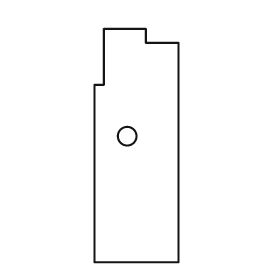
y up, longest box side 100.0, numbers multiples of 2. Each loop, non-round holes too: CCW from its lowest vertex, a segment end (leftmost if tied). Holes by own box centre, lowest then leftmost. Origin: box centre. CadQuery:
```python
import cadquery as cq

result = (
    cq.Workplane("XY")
    .moveTo(-18.0, -50.0)
    .lineTo(18.0, -50.0)
    .lineTo(18.0, 44.0)
    .lineTo(4.0, 44.0)
    .lineTo(4.0, 50.0)
    .lineTo(-14.0, 50.0)
    .lineTo(-14.0, 26.0)
    .lineTo(-18.0, 26.0)
    .close()
    .moveTo(-4.0, 4.0)
    .circle(4.0)
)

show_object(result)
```